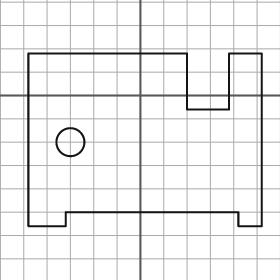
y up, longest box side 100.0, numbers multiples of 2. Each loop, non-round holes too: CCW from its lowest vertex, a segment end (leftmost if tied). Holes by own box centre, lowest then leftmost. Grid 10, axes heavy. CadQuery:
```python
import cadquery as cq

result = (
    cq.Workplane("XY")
    .moveTo(-48.0, -56.0)
    .lineTo(-32.0, -56.0)
    .lineTo(-32.0, -50.0)
    .lineTo(42.0, -50.0)
    .lineTo(42.0, -56.0)
    .lineTo(52.0, -56.0)
    .lineTo(52.0, 18.0)
    .lineTo(38.0, 18.0)
    .lineTo(38.0, -6.0)
    .lineTo(20.0, -6.0)
    .lineTo(20.0, 18.0)
    .lineTo(-48.0, 18.0)
    .close()
    .moveTo(-30.0, -20.0)
    .circle(6.0)
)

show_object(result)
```